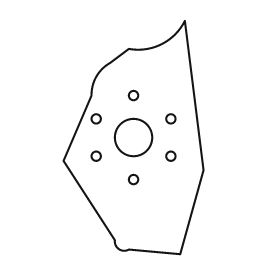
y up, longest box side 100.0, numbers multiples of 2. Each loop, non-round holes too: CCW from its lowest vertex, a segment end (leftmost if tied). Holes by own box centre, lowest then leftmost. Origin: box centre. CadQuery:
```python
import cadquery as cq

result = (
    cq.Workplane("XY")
    .moveTo(20.0, -50.0)
    .lineTo(30.0, -14.0)
    .lineTo(22.0, 50.0)
    .threePointArc((12.0, 40.0), (-2.0, 38.0))
    .lineTo(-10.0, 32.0)
    .threePointArc((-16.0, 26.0), (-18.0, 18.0))
    .lineTo(-30.0, -10.0)
    .lineTo(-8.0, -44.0)
    .threePointArc((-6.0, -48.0), (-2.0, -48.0))
    .close()
    .moveTo(0.0, -18.0)
    .circle(2.0)
    .moveTo(-16.0, -8.0)
    .circle(2.0)
    .moveTo(16.0, -8.0)
    .circle(2.0)
    .moveTo(0.0, 0.0)
    .circle(8.0)
    .moveTo(-16.0, 8.0)
    .circle(2.0)
    .moveTo(16.0, 8.0)
    .circle(2.0)
    .moveTo(0.0, 18.0)
    .circle(2.0)
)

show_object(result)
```